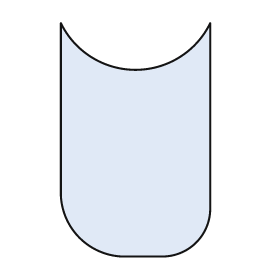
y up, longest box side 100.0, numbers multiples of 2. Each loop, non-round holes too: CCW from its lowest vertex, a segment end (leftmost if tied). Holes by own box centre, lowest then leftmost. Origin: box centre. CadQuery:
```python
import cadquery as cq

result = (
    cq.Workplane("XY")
    .moveTo(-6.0, -50.0)
    .lineTo(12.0, -50.0)
    .threePointArc((26.0, -44.0), (32.0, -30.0))
    .lineTo(32.0, 50.0)
    .threePointArc((0.0, 30.0), (-32.0, 50.0))
    .lineTo(-32.0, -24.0)
    .threePointArc((-24.0, -42.0), (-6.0, -50.0))
    .close()
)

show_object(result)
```